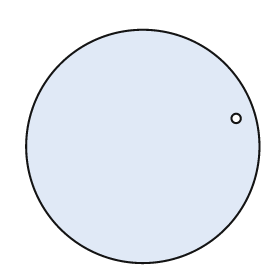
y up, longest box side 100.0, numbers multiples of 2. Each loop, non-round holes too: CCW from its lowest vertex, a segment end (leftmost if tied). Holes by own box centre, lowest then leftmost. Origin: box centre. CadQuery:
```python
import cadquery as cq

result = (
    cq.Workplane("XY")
    .moveTo(0.0, 0.0)
    .circle(50.0)
    .moveTo(40.0, 12.0)
    .circle(2.0)
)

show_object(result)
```